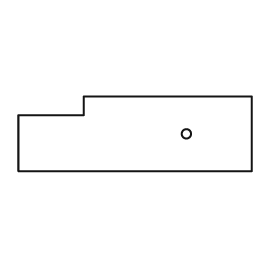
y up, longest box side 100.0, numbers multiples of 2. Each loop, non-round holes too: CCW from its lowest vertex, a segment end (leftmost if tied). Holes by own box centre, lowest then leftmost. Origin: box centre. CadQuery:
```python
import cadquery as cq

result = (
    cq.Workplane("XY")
    .moveTo(-50.0, -16.0)
    .lineTo(50.0, -16.0)
    .lineTo(50.0, 16.0)
    .lineTo(-22.0, 16.0)
    .lineTo(-22.0, 8.0)
    .lineTo(-50.0, 8.0)
    .close()
    .moveTo(22.0, 0.0)
    .circle(2.0)
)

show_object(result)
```